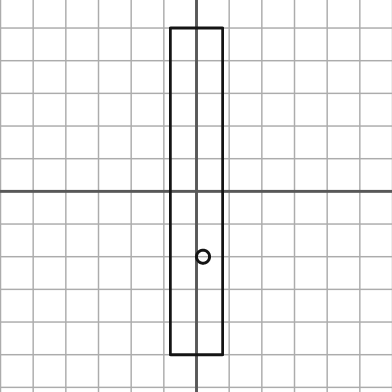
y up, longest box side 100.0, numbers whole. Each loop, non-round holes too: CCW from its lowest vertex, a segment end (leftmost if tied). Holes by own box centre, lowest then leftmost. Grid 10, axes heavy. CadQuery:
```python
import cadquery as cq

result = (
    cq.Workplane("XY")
    .moveTo(-8.0, -50.0)
    .lineTo(8.0, -50.0)
    .lineTo(8.0, 50.0)
    .lineTo(-8.0, 50.0)
    .close()
    .moveTo(2.0, -20.0)
    .circle(2.0)
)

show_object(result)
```